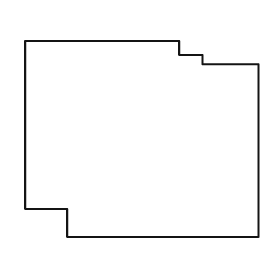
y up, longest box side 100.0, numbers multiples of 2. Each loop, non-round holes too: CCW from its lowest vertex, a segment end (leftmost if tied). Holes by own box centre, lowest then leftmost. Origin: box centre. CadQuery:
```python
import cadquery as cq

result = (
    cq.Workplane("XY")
    .moveTo(-32.0, -42.0)
    .lineTo(50.0, -42.0)
    .lineTo(50.0, 32.0)
    .lineTo(26.0, 32.0)
    .lineTo(26.0, 36.0)
    .lineTo(16.0, 36.0)
    .lineTo(16.0, 42.0)
    .lineTo(-50.0, 42.0)
    .lineTo(-50.0, -30.0)
    .lineTo(-32.0, -30.0)
    .close()
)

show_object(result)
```